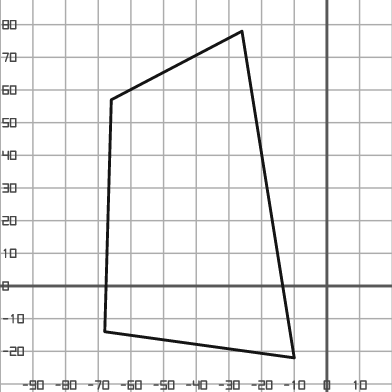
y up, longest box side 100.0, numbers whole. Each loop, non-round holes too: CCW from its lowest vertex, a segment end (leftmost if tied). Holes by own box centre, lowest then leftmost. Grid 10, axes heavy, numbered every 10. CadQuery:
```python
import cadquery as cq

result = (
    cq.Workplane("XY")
    .moveTo(-10.0, -22.0)
    .lineTo(-26.0, 78.0)
    .lineTo(-66.0, 57.0)
    .lineTo(-68.0, -14.0)
    .close()
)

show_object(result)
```